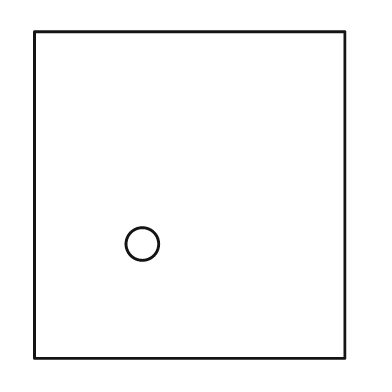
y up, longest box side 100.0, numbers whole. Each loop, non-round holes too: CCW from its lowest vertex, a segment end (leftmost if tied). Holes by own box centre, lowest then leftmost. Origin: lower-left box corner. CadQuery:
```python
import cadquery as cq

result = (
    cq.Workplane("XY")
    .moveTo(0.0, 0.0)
    .lineTo(95.0, 0.0)
    .lineTo(95.0, 100.0)
    .lineTo(0.0, 100.0)
    .close()
    .moveTo(33.0, 35.0)
    .circle(5.0)
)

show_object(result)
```